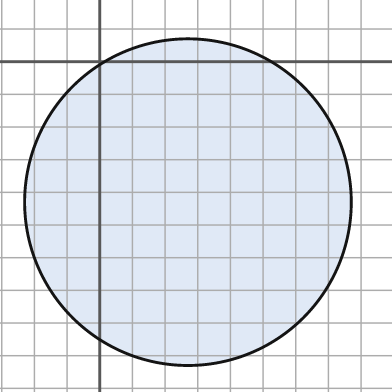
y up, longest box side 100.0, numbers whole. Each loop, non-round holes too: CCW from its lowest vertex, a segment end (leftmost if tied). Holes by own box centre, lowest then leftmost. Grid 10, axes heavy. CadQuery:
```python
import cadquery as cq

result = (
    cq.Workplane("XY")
    .moveTo(27.0, -43.0)
    .circle(50.0)
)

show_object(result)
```